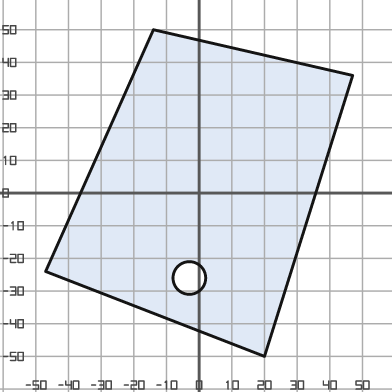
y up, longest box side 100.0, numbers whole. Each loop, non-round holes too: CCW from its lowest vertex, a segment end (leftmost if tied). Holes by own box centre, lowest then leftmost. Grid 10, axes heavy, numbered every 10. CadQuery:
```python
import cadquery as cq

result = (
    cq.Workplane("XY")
    .moveTo(20.0, -50.0)
    .lineTo(47.0, 36.0)
    .lineTo(-14.0, 50.0)
    .lineTo(-47.0, -24.0)
    .close()
    .moveTo(-3.0, -26.0)
    .circle(5.0)
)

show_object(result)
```